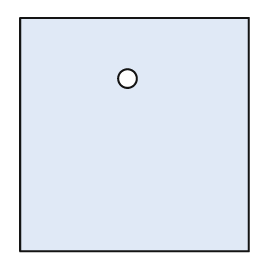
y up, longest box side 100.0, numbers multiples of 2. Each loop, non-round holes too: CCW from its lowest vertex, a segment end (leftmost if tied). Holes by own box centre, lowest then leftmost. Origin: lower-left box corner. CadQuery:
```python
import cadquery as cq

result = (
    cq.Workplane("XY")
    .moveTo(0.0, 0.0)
    .lineTo(98.0, 0.0)
    .lineTo(98.0, 100.0)
    .lineTo(0.0, 100.0)
    .close()
    .moveTo(46.0, 74.0)
    .circle(4.0)
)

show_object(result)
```